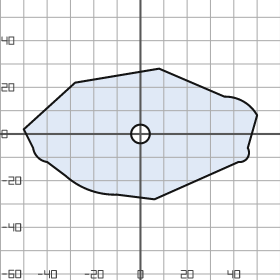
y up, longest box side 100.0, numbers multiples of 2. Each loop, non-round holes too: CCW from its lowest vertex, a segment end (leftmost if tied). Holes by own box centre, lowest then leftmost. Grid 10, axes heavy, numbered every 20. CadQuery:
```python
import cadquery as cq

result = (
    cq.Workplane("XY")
    .moveTo(6.0, -28.0)
    .lineTo(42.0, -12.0)
    .threePointArc((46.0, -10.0), (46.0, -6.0))
    .lineTo(50.0, 8.0)
    .threePointArc((44.0, 14.0), (36.0, 16.0))
    .lineTo(8.0, 28.0)
    .lineTo(-28.0, 22.0)
    .lineTo(-50.0, 2.0)
    .lineTo(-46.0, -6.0)
    .threePointArc((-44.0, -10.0), (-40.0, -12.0))
    .lineTo(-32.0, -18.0)
    .threePointArc((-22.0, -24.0), (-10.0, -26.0))
    .close()
    .moveTo(0.0, 0.0)
    .circle(4.0)
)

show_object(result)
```